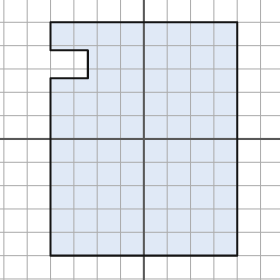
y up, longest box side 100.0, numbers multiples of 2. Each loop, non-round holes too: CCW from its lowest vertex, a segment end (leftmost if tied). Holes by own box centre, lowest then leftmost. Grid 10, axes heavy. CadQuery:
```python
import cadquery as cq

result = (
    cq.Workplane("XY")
    .moveTo(-40.0, -50.0)
    .lineTo(40.0, -50.0)
    .lineTo(40.0, 50.0)
    .lineTo(-40.0, 50.0)
    .lineTo(-40.0, 38.0)
    .lineTo(-24.0, 38.0)
    .lineTo(-24.0, 26.0)
    .lineTo(-40.0, 26.0)
    .close()
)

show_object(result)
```